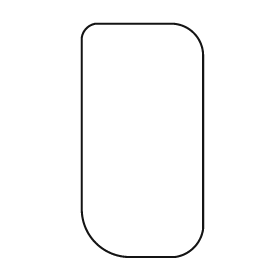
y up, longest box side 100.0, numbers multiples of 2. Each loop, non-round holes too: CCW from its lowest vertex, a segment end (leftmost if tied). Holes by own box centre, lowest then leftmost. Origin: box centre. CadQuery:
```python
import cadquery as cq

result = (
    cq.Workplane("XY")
    .moveTo(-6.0, -50.0)
    .lineTo(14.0, -50.0)
    .threePointArc((22.0, -46.0), (26.0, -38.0))
    .lineTo(26.0, 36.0)
    .threePointArc((22.0, 46.0), (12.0, 50.0))
    .lineTo(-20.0, 50.0)
    .threePointArc((-24.0, 48.0), (-26.0, 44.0))
    .lineTo(-26.0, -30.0)
    .threePointArc((-20.0, -44.0), (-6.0, -50.0))
    .close()
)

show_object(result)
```